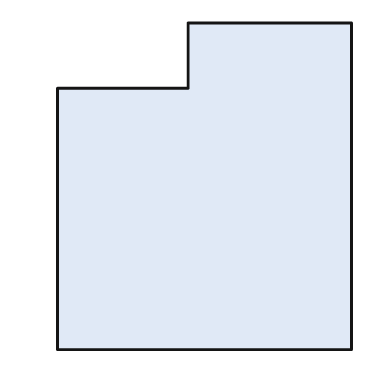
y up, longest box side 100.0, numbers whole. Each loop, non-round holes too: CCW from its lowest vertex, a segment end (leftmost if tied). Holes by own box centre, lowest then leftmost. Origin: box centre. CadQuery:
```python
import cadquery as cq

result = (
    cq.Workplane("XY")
    .moveTo(-45.0, -50.0)
    .lineTo(45.0, -50.0)
    .lineTo(45.0, 50.0)
    .lineTo(-5.0, 50.0)
    .lineTo(-5.0, 30.0)
    .lineTo(-45.0, 30.0)
    .close()
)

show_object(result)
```